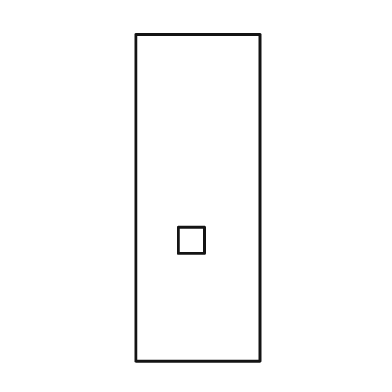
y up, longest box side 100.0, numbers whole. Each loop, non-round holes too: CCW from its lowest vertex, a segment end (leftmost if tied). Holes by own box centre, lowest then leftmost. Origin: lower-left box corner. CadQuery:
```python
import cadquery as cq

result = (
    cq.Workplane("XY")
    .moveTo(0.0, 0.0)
    .lineTo(38.0, 0.0)
    .lineTo(38.0, 100.0)
    .lineTo(0.0, 100.0)
    .close()
    .moveTo(13.0, 33.0)
    .lineTo(21.0, 33.0)
    .lineTo(21.0, 41.0)
    .lineTo(13.0, 41.0)
    .close()
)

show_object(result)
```